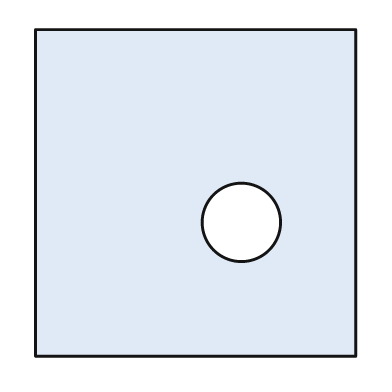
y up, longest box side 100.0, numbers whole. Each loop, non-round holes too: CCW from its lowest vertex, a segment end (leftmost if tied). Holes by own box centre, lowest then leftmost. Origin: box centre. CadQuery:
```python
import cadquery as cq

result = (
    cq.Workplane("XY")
    .moveTo(-49.0, -50.0)
    .lineTo(49.0, -50.0)
    .lineTo(49.0, 50.0)
    .lineTo(-49.0, 50.0)
    .close()
    .moveTo(14.0, -9.0)
    .circle(12.0)
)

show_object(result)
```